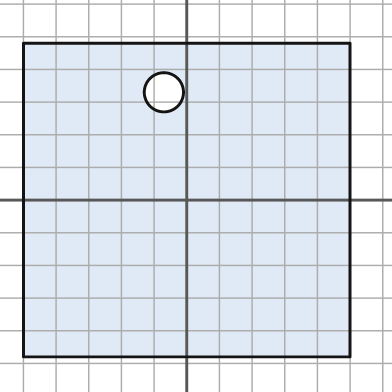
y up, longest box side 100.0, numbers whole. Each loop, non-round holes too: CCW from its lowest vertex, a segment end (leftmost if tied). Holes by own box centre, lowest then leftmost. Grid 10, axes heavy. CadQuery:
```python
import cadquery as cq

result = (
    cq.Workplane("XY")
    .moveTo(-50.0, -48.0)
    .lineTo(50.0, -48.0)
    .lineTo(50.0, 48.0)
    .lineTo(-50.0, 48.0)
    .close()
    .moveTo(-7.0, 33.0)
    .circle(6.0)
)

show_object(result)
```